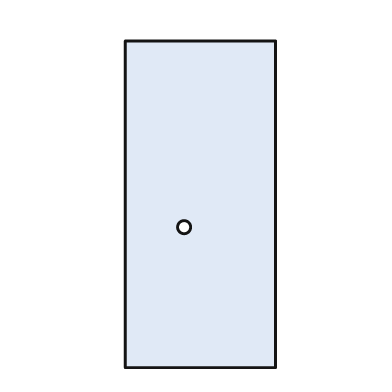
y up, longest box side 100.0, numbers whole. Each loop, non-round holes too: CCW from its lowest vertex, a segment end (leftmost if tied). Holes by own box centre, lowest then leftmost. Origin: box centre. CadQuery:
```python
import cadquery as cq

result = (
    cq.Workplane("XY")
    .moveTo(-23.0, -50.0)
    .lineTo(23.0, -50.0)
    .lineTo(23.0, 50.0)
    .lineTo(-23.0, 50.0)
    .close()
    .moveTo(-5.0, -7.0)
    .circle(2.0)
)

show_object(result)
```